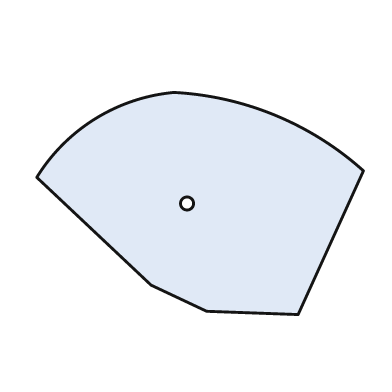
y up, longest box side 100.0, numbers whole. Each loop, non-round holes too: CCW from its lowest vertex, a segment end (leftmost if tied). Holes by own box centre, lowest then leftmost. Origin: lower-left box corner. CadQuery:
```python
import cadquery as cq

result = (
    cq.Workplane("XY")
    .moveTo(80.0, 0.0)
    .lineTo(100.0, 44.0)
    .threePointArc((73.0, 61.0), (42.0, 68.0))
    .threePointArc((18.0, 60.0), (0.0, 42.0))
    .lineTo(35.0, 9.0)
    .lineTo(52.0, 1.0)
    .close()
    .moveTo(46.0, 34.0)
    .circle(2.0)
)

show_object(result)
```